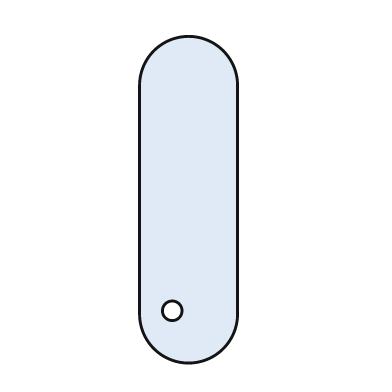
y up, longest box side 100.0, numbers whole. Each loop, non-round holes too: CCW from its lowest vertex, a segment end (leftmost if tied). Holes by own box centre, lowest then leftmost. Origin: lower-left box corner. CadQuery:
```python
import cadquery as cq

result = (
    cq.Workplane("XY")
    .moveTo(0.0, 15.0)
    .threePointArc((15.0, 0.0), (30.0, 15.0))
    .lineTo(30.0, 85.0)
    .threePointArc((15.0, 100.0), (0.0, 85.0))
    .close()
    .moveTo(10.0, 16.0)
    .circle(3.0)
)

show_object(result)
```